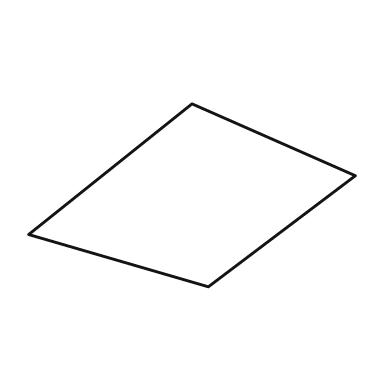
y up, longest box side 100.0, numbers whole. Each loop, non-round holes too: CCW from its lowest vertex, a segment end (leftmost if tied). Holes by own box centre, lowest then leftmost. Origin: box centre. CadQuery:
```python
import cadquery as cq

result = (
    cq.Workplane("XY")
    .moveTo(5.0, -28.0)
    .lineTo(50.0, 6.0)
    .lineTo(0.0, 28.0)
    .lineTo(-50.0, -12.0)
    .close()
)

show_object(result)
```